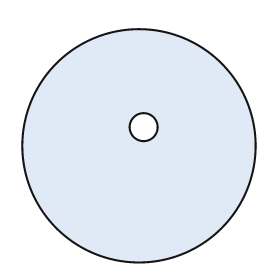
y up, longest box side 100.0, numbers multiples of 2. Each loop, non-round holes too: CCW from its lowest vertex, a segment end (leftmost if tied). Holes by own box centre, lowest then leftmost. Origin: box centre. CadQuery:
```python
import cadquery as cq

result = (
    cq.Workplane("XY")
    .moveTo(0.0, 0.0)
    .circle(50.0)
    .moveTo(2.0, 8.0)
    .circle(6.0)
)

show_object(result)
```